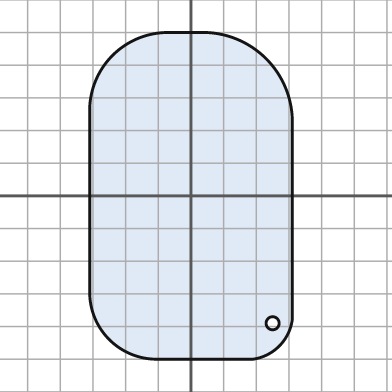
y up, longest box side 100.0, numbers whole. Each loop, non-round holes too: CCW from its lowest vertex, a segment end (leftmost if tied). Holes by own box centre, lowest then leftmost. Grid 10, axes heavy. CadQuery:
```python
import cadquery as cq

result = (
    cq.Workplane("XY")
    .moveTo(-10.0, -50.0)
    .lineTo(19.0, -50.0)
    .threePointArc((27.0, -46.0), (31.0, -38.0))
    .lineTo(31.0, 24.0)
    .threePointArc((23.0, 42.0), (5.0, 50.0))
    .lineTo(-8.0, 50.0)
    .threePointArc((-24.0, 43.0), (-31.0, 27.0))
    .lineTo(-31.0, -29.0)
    .threePointArc((-25.0, -44.0), (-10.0, -50.0))
    .close()
    .moveTo(25.0, -39.0)
    .circle(2.0)
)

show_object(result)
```